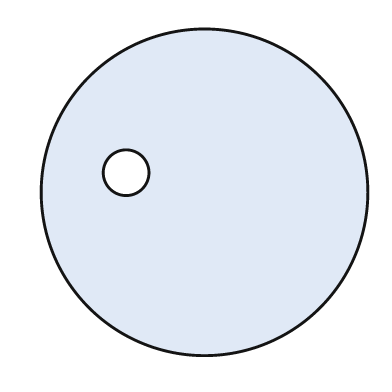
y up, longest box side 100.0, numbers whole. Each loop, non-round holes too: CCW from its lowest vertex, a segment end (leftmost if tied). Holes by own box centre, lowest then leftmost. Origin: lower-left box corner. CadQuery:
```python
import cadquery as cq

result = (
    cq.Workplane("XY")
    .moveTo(50.0, 50.0)
    .circle(50.0)
    .moveTo(26.0, 56.0)
    .circle(7.0)
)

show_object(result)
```